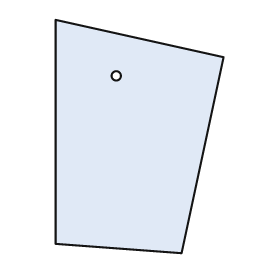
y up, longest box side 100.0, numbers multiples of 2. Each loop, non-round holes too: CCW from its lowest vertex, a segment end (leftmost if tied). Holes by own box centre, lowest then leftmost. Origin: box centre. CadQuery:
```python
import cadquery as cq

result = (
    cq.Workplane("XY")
    .moveTo(18.0, -50.0)
    .lineTo(36.0, 34.0)
    .lineTo(-36.0, 50.0)
    .lineTo(-36.0, -46.0)
    .close()
    .moveTo(-10.0, 26.0)
    .circle(2.0)
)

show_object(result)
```